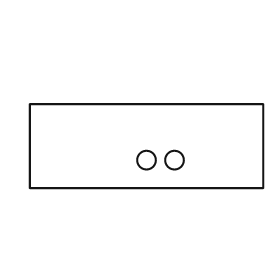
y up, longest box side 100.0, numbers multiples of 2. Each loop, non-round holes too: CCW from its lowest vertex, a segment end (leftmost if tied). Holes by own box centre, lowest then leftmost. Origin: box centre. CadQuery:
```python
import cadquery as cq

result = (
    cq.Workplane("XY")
    .moveTo(-50.0, -18.0)
    .lineTo(50.0, -18.0)
    .lineTo(50.0, 18.0)
    .lineTo(-50.0, 18.0)
    .close()
    .moveTo(0.0, -6.0)
    .circle(4.0)
    .moveTo(12.0, -6.0)
    .circle(4.0)
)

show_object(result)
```